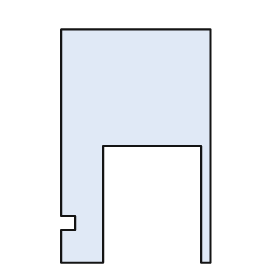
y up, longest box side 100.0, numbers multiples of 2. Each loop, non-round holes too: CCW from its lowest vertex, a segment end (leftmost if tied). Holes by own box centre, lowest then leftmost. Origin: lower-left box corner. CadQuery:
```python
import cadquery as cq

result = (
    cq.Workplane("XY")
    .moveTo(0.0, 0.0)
    .lineTo(18.0, 0.0)
    .lineTo(18.0, 50.0)
    .lineTo(60.0, 50.0)
    .lineTo(60.0, 0.0)
    .lineTo(64.0, 0.0)
    .lineTo(64.0, 100.0)
    .lineTo(0.0, 100.0)
    .lineTo(0.0, 20.0)
    .lineTo(6.0, 20.0)
    .lineTo(6.0, 14.0)
    .lineTo(0.0, 14.0)
    .close()
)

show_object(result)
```